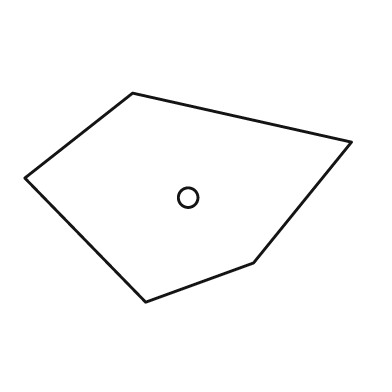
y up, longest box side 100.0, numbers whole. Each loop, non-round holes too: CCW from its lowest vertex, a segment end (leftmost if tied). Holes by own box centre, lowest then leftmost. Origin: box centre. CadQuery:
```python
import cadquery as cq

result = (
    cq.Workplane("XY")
    .moveTo(-13.0, -32.0)
    .lineTo(20.0, -20.0)
    .lineTo(50.0, 17.0)
    .lineTo(-17.0, 32.0)
    .lineTo(-50.0, 6.0)
    .close()
    .moveTo(0.0, 0.0)
    .circle(3.0)
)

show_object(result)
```